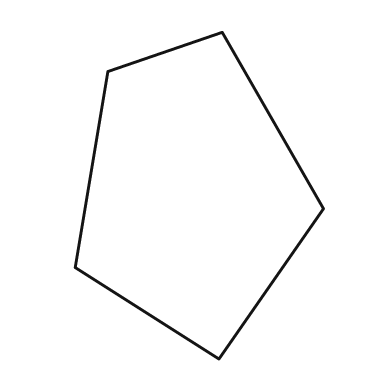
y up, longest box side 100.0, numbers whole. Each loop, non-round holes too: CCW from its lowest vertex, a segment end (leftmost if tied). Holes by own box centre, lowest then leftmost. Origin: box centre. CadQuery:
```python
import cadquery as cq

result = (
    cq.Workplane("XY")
    .moveTo(6.0, -50.0)
    .lineTo(38.0, -4.0)
    .lineTo(7.0, 50.0)
    .lineTo(-28.0, 38.0)
    .lineTo(-38.0, -22.0)
    .close()
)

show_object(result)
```